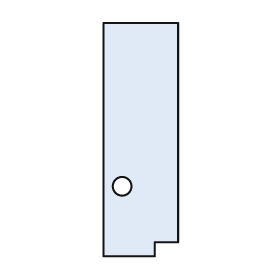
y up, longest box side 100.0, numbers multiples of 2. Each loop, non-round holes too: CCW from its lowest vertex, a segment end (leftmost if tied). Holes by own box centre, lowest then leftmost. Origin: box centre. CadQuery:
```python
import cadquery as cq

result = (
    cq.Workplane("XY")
    .moveTo(-16.0, -50.0)
    .lineTo(6.0, -50.0)
    .lineTo(6.0, -44.0)
    .lineTo(16.0, -44.0)
    .lineTo(16.0, 50.0)
    .lineTo(-16.0, 50.0)
    .close()
    .moveTo(-8.0, -20.0)
    .circle(4.0)
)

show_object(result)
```